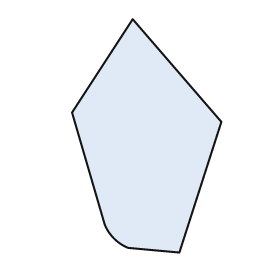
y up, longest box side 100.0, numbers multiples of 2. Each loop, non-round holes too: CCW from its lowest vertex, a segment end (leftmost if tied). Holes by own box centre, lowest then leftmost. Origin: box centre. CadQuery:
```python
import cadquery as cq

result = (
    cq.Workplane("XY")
    .moveTo(14.0, -50.0)
    .lineTo(32.0, 6.0)
    .lineTo(-6.0, 50.0)
    .lineTo(-32.0, 10.0)
    .lineTo(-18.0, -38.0)
    .threePointArc((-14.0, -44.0), (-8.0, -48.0))
    .close()
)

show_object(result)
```